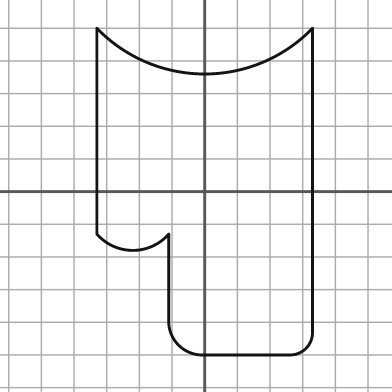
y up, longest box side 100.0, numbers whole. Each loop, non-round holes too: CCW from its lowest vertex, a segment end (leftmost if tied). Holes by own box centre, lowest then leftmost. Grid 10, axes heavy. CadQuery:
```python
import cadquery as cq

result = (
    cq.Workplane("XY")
    .moveTo(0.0, -50.0)
    .lineTo(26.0, -50.0)
    .threePointArc((31.0, -48.0), (33.0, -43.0))
    .lineTo(33.0, 50.0)
    .threePointArc((0.0, 36.0), (-33.0, 50.0))
    .lineTo(-33.0, -13.0)
    .threePointArc((-22.0, -18.0), (-11.0, -13.0))
    .lineTo(-11.0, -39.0)
    .threePointArc((-8.0, -47.0), (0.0, -50.0))
    .close()
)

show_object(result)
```